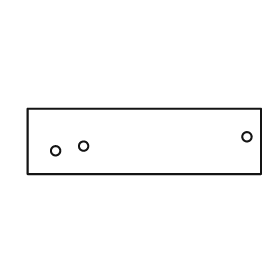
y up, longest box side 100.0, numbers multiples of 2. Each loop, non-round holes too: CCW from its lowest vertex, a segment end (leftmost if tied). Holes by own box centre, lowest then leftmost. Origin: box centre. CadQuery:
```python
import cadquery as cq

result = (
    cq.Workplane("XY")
    .moveTo(-50.0, -14.0)
    .lineTo(50.0, -14.0)
    .lineTo(50.0, 14.0)
    .lineTo(-50.0, 14.0)
    .close()
    .moveTo(-38.0, -4.0)
    .circle(2.0)
    .moveTo(-26.0, -2.0)
    .circle(2.0)
    .moveTo(44.0, 2.0)
    .circle(2.0)
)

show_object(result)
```